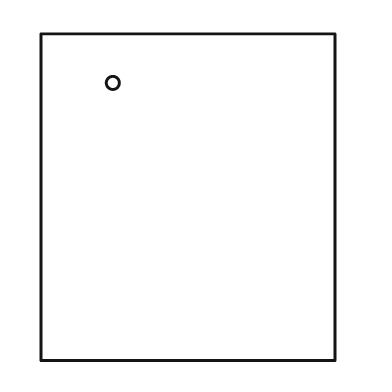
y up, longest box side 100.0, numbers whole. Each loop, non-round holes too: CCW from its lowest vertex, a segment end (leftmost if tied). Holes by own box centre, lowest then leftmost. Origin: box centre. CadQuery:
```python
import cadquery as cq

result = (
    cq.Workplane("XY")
    .moveTo(-45.0, -50.0)
    .lineTo(45.0, -50.0)
    .lineTo(45.0, 50.0)
    .lineTo(-45.0, 50.0)
    .close()
    .moveTo(-23.0, 35.0)
    .circle(2.0)
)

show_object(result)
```